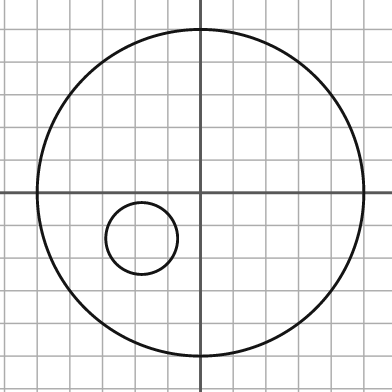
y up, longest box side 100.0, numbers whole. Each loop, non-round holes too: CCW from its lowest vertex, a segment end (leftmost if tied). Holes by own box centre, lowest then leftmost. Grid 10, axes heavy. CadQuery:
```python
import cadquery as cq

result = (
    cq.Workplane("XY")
    .moveTo(0.0, 0.0)
    .circle(50.0)
    .moveTo(-18.0, -14.0)
    .circle(11.0)
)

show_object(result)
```